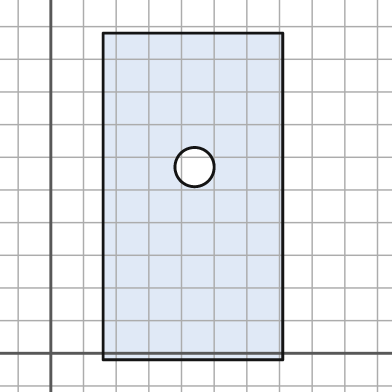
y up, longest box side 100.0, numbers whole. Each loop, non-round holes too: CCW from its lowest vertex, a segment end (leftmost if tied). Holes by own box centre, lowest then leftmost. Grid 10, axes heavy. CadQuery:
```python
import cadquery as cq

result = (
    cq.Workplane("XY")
    .moveTo(16.0, -2.0)
    .lineTo(71.0, -2.0)
    .lineTo(71.0, 98.0)
    .lineTo(16.0, 98.0)
    .close()
    .moveTo(44.0, 57.0)
    .circle(6.0)
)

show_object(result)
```